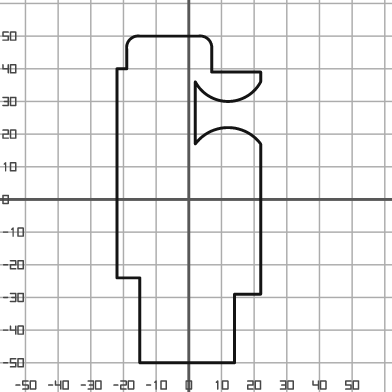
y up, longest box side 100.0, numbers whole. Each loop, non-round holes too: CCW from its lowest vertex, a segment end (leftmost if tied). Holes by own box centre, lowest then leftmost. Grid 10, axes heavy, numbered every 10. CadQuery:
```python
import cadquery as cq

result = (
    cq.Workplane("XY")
    .moveTo(-15.0, -50.0)
    .lineTo(14.0, -50.0)
    .lineTo(14.0, -29.0)
    .lineTo(22.0, -29.0)
    .lineTo(22.0, 17.0)
    .threePointArc((12.0, 22.0), (2.0, 17.0))
    .lineTo(2.0, 36.0)
    .threePointArc((12.0, 30.0), (22.0, 36.0))
    .lineTo(22.0, 39.0)
    .lineTo(7.0, 39.0)
    .lineTo(7.0, 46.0)
    .threePointArc((6.0, 49.0), (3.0, 50.0))
    .lineTo(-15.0, 50.0)
    .threePointArc((-18.0, 49.0), (-19.0, 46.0))
    .lineTo(-19.0, 40.0)
    .lineTo(-22.0, 40.0)
    .lineTo(-22.0, -24.0)
    .lineTo(-15.0, -24.0)
    .close()
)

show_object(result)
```